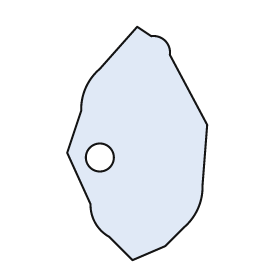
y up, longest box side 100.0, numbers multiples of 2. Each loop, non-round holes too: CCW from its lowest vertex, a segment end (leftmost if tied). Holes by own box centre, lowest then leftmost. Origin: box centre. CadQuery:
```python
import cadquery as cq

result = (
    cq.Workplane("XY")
    .moveTo(-2.0, -50.0)
    .lineTo(12.0, -44.0)
    .lineTo(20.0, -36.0)
    .threePointArc((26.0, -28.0), (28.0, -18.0))
    .lineTo(30.0, 8.0)
    .lineTo(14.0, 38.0)
    .threePointArc((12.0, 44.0), (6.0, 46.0))
    .lineTo(0.0, 50.0)
    .lineTo(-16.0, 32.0)
    .threePointArc((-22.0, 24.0), (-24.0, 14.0))
    .lineTo(-30.0, -4.0)
    .lineTo(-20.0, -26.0)
    .threePointArc((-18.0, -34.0), (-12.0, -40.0))
    .close()
    .moveTo(-16.0, -6.0)
    .circle(6.0)
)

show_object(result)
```